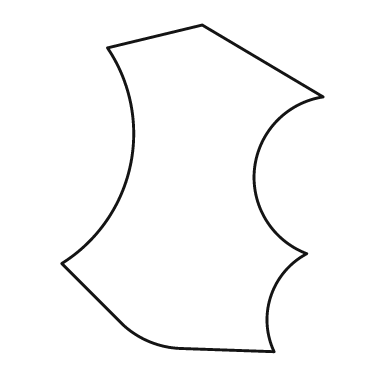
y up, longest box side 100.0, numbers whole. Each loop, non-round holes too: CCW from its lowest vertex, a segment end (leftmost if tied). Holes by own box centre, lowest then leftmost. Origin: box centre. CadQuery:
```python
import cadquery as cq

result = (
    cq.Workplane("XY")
    .moveTo(25.0, -50.0)
    .threePointArc((24.0, -33.0), (35.0, -20.0))
    .threePointArc((19.0, 6.0), (40.0, 28.0))
    .lineTo(3.0, 50.0)
    .lineTo(-26.0, 43.0)
    .threePointArc((-19.0, 7.0), (-40.0, -23.0))
    .lineTo(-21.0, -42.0)
    .threePointArc((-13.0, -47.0), (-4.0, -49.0))
    .close()
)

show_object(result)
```